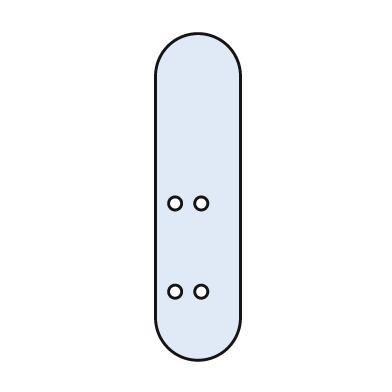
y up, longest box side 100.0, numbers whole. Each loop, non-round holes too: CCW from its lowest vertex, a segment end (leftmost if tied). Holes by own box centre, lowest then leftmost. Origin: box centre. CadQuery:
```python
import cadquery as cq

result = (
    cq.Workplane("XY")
    .moveTo(-13.0, -37.0)
    .threePointArc((0.0, -50.0), (13.0, -37.0))
    .lineTo(13.0, 37.0)
    .threePointArc((0.0, 50.0), (-13.0, 37.0))
    .close()
    .moveTo(-7.0, -29.0)
    .circle(2.0)
    .moveTo(1.0, -29.0)
    .circle(2.0)
    .moveTo(-7.0, -2.0)
    .circle(2.0)
    .moveTo(1.0, -2.0)
    .circle(2.0)
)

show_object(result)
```